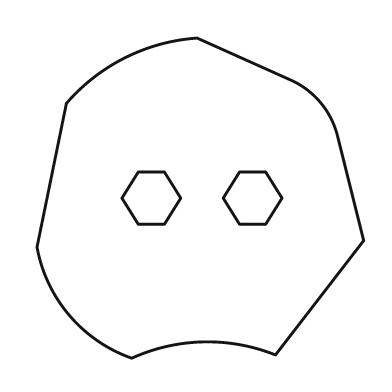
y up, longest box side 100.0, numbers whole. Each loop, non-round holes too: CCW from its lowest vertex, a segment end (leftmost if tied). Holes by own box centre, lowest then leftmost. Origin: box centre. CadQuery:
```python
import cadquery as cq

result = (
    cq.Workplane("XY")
    .moveTo(-21.0, -49.0)
    .threePointArc((1.0, -44.0), (23.0, -48.0))
    .lineTo(50.0, -13.0)
    .lineTo(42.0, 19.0)
    .threePointArc((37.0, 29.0), (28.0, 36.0))
    .lineTo(-1.0, 49.0)
    .threePointArc((-23.0, 43.0), (-41.0, 29.0))
    .lineTo(-50.0, -15.0)
    .threePointArc((-40.0, -36.0), (-21.0, -49.0))
    .close()
    .moveTo(-19.0, -8.0)
    .lineTo(-11.0, -8.0)
    .lineTo(-6.0, 0.0)
    .lineTo(-11.0, 8.0)
    .lineTo(-19.0, 8.0)
    .lineTo(-24.0, 0.0)
    .close()
    .moveTo(12.0, -8.0)
    .lineTo(20.0, -8.0)
    .lineTo(25.0, 0.0)
    .lineTo(20.0, 8.0)
    .lineTo(12.0, 8.0)
    .lineTo(7.0, 0.0)
    .close()
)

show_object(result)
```